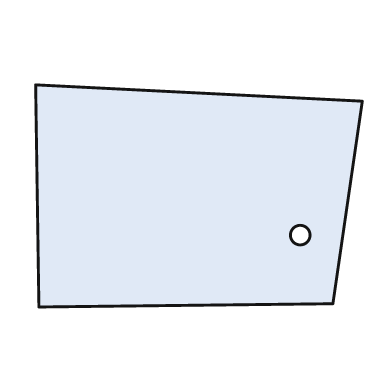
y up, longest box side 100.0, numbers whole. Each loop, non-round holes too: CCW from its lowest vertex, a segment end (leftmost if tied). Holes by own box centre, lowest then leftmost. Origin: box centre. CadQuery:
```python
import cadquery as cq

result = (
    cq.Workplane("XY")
    .moveTo(-49.0, -34.0)
    .lineTo(41.0, -33.0)
    .lineTo(50.0, 29.0)
    .lineTo(-50.0, 34.0)
    .close()
    .moveTo(31.0, -12.0)
    .circle(3.0)
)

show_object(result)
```